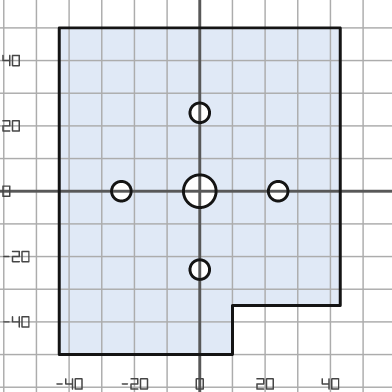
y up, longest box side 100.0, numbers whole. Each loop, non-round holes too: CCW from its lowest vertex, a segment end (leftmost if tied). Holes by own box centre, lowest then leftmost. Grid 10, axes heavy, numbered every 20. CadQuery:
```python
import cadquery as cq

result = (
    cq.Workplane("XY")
    .moveTo(-43.0, -50.0)
    .lineTo(10.0, -50.0)
    .lineTo(10.0, -35.0)
    .lineTo(43.0, -35.0)
    .lineTo(43.0, 50.0)
    .lineTo(-43.0, 50.0)
    .close()
    .moveTo(0.0, -24.0)
    .circle(3.0)
    .moveTo(-24.0, 0.0)
    .circle(3.0)
    .moveTo(0.0, 0.0)
    .circle(5.0)
    .moveTo(24.0, 0.0)
    .circle(3.0)
    .moveTo(0.0, 24.0)
    .circle(3.0)
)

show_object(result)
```